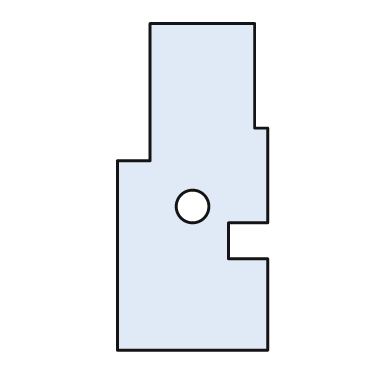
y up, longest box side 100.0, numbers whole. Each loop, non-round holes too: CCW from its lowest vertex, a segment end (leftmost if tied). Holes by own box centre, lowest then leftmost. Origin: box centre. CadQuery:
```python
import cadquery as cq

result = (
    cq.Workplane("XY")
    .moveTo(-23.0, -50.0)
    .lineTo(23.0, -50.0)
    .lineTo(23.0, -22.0)
    .lineTo(11.0, -22.0)
    .lineTo(11.0, -11.0)
    .lineTo(23.0, -11.0)
    .lineTo(23.0, 18.0)
    .lineTo(19.0, 18.0)
    .lineTo(19.0, 50.0)
    .lineTo(-13.0, 50.0)
    .lineTo(-13.0, 8.0)
    .lineTo(-23.0, 8.0)
    .close()
    .moveTo(0.0, -6.0)
    .circle(5.0)
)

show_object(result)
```